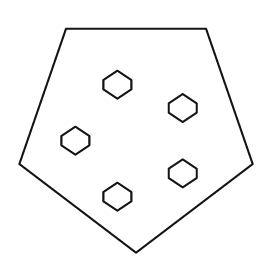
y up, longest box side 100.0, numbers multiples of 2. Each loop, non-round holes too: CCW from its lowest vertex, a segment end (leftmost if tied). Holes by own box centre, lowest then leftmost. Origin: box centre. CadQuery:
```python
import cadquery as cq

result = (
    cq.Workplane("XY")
    .moveTo(0.0, -48.0)
    .lineTo(50.0, -10.0)
    .lineTo(30.0, 48.0)
    .lineTo(-30.0, 48.0)
    .lineTo(-50.0, -10.0)
    .close()
    .moveTo(-8.0, -30.0)
    .lineTo(-2.0, -26.0)
    .lineTo(-2.0, -22.0)
    .lineTo(-8.0, -18.0)
    .lineTo(-14.0, -22.0)
    .lineTo(-14.0, -26.0)
    .close()
    .moveTo(20.0, -20.0)
    .lineTo(26.0, -16.0)
    .lineTo(26.0, -12.0)
    .lineTo(20.0, -8.0)
    .lineTo(14.0, -12.0)
    .lineTo(14.0, -16.0)
    .close()
    .moveTo(-26.0, -6.0)
    .lineTo(-20.0, -2.0)
    .lineTo(-20.0, 2.0)
    .lineTo(-26.0, 6.0)
    .lineTo(-32.0, 2.0)
    .lineTo(-32.0, -2.0)
    .close()
    .moveTo(20.0, 8.0)
    .lineTo(26.0, 12.0)
    .lineTo(26.0, 16.0)
    .lineTo(20.0, 20.0)
    .lineTo(14.0, 16.0)
    .lineTo(14.0, 12.0)
    .close()
    .moveTo(-8.0, 18.0)
    .lineTo(-2.0, 22.0)
    .lineTo(-2.0, 26.0)
    .lineTo(-8.0, 30.0)
    .lineTo(-14.0, 26.0)
    .lineTo(-14.0, 22.0)
    .close()
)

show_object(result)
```